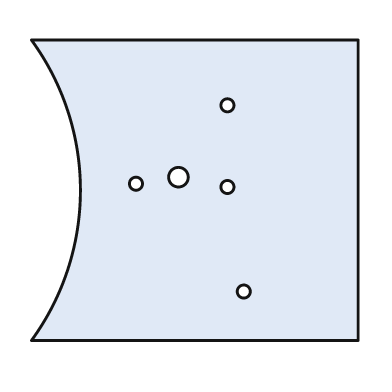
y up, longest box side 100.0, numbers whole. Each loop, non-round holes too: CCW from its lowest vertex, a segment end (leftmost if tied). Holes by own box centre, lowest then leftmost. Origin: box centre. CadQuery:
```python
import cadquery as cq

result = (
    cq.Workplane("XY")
    .moveTo(-50.0, -46.0)
    .lineTo(50.0, -46.0)
    .lineTo(50.0, 46.0)
    .lineTo(-50.0, 46.0)
    .threePointArc((-35.0, 0.0), (-50.0, -46.0))
    .close()
    .moveTo(15.0, -31.0)
    .circle(2.0)
    .moveTo(10.0, 1.0)
    .circle(2.0)
    .moveTo(-18.0, 2.0)
    .circle(2.0)
    .moveTo(-5.0, 4.0)
    .circle(3.0)
    .moveTo(10.0, 26.0)
    .circle(2.0)
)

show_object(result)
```